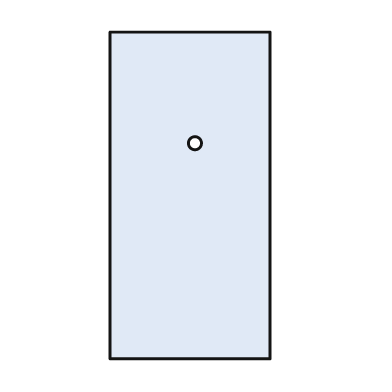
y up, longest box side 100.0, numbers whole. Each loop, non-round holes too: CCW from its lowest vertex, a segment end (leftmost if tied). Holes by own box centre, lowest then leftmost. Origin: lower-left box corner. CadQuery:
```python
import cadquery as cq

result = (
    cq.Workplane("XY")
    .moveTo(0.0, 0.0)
    .lineTo(49.0, 0.0)
    .lineTo(49.0, 100.0)
    .lineTo(0.0, 100.0)
    .close()
    .moveTo(26.0, 66.0)
    .circle(2.0)
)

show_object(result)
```